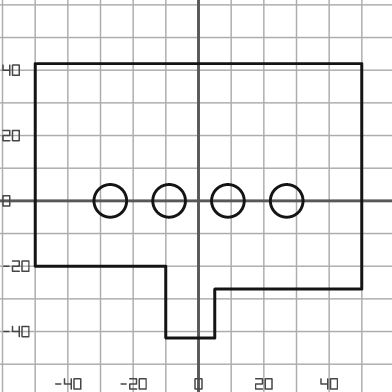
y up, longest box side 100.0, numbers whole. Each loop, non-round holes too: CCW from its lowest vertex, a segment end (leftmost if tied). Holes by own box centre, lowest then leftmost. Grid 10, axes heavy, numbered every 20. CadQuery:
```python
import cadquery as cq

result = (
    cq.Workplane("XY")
    .moveTo(-10.0, -42.0)
    .lineTo(5.0, -42.0)
    .lineTo(5.0, -27.0)
    .lineTo(50.0, -27.0)
    .lineTo(50.0, 42.0)
    .lineTo(-50.0, 42.0)
    .lineTo(-50.0, -20.0)
    .lineTo(-10.0, -20.0)
    .close()
    .moveTo(-27.0, 0.0)
    .circle(5.0)
    .moveTo(-9.0, 0.0)
    .circle(5.0)
    .moveTo(9.0, 0.0)
    .circle(5.0)
    .moveTo(27.0, 0.0)
    .circle(5.0)
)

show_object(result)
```